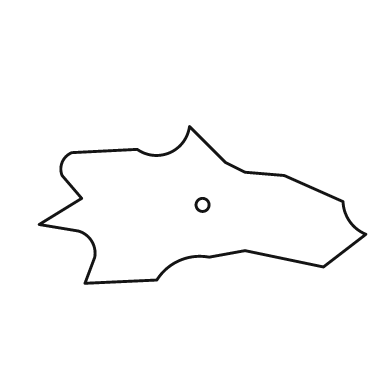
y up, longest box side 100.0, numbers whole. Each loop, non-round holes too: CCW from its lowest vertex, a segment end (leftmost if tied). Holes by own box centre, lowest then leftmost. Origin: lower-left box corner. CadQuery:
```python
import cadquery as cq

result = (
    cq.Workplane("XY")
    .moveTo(14.0, 0.0)
    .lineTo(36.0, 1.0)
    .threePointArc((43.0, 7.0), (52.0, 8.0))
    .lineTo(63.0, 10.0)
    .lineTo(87.0, 5.0)
    .lineTo(100.0, 15.0)
    .threePointArc((95.0, 19.0), (93.0, 25.0))
    .lineTo(75.0, 33.0)
    .lineTo(63.0, 34.0)
    .lineTo(57.0, 37.0)
    .lineTo(46.0, 48.0)
    .threePointArc((40.0, 40.0), (30.0, 41.0))
    .lineTo(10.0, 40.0)
    .threePointArc((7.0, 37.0), (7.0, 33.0))
    .lineTo(13.0, 26.0)
    .lineTo(0.0, 18.0)
    .lineTo(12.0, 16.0)
    .threePointArc((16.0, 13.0), (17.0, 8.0))
    .close()
    .moveTo(50.0, 24.0)
    .circle(2.0)
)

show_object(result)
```